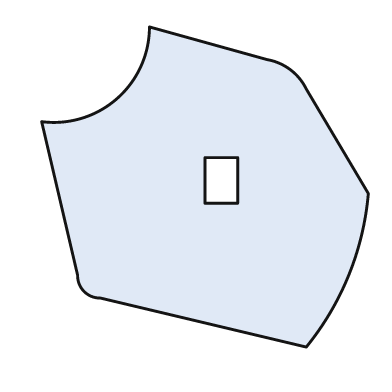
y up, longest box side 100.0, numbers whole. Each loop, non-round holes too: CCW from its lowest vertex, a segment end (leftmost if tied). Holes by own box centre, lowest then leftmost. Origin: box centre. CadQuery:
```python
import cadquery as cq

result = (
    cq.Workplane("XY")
    .moveTo(31.0, -49.0)
    .threePointArc((44.0, -27.0), (50.0, -2.0))
    .lineTo(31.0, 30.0)
    .threePointArc((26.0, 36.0), (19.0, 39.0))
    .lineTo(-17.0, 49.0)
    .threePointArc((-27.0, 27.0), (-50.0, 20.0))
    .lineTo(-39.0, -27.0)
    .threePointArc((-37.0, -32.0), (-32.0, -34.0))
    .close()
    .moveTo(0.0, -5.0)
    .lineTo(10.0, -5.0)
    .lineTo(10.0, 9.0)
    .lineTo(0.0, 9.0)
    .close()
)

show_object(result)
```